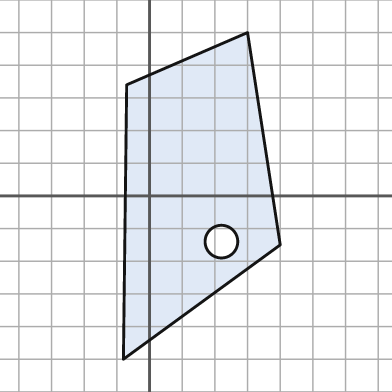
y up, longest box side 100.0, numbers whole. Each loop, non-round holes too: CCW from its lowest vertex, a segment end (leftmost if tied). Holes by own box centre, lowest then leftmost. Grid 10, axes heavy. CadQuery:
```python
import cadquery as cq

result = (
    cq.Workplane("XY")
    .moveTo(-8.0, -50.0)
    .lineTo(40.0, -15.0)
    .lineTo(30.0, 50.0)
    .lineTo(-7.0, 34.0)
    .close()
    .moveTo(22.0, -14.0)
    .circle(5.0)
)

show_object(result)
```